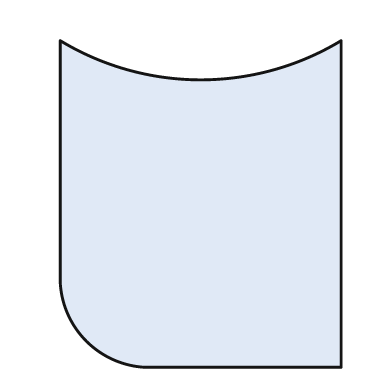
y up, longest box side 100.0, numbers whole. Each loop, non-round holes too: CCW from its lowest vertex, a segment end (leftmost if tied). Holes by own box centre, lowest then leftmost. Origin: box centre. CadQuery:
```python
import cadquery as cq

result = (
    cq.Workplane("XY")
    .moveTo(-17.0, -50.0)
    .lineTo(43.0, -50.0)
    .lineTo(43.0, 50.0)
    .threePointArc((0.0, 38.0), (-43.0, 50.0))
    .lineTo(-43.0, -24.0)
    .threePointArc((-35.0, -42.0), (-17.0, -50.0))
    .close()
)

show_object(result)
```